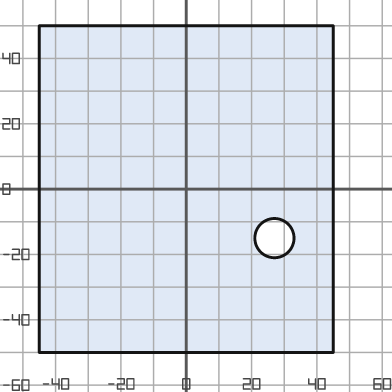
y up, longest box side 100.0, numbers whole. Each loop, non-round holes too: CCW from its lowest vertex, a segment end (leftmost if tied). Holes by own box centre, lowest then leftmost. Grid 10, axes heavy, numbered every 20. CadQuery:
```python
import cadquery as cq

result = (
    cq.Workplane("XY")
    .moveTo(-45.0, -50.0)
    .lineTo(45.0, -50.0)
    .lineTo(45.0, 50.0)
    .lineTo(-45.0, 50.0)
    .close()
    .moveTo(27.0, -15.0)
    .circle(6.0)
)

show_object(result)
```